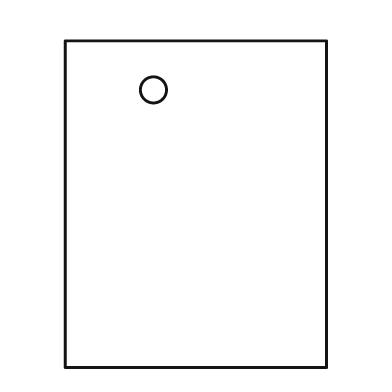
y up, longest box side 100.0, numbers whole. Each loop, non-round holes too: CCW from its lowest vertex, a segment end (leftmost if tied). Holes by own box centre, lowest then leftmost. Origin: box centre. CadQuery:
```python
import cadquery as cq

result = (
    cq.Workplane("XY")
    .moveTo(-40.0, -50.0)
    .lineTo(40.0, -50.0)
    .lineTo(40.0, 50.0)
    .lineTo(-40.0, 50.0)
    .close()
    .moveTo(-13.0, 35.0)
    .circle(4.0)
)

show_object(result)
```